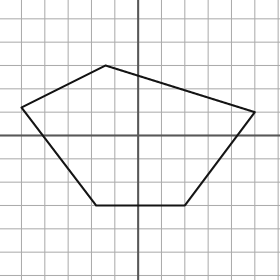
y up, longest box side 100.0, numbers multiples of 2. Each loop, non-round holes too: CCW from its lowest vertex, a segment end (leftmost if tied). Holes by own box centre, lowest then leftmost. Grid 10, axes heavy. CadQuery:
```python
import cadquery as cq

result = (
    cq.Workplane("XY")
    .moveTo(-18.0, -30.0)
    .lineTo(20.0, -30.0)
    .lineTo(50.0, 10.0)
    .lineTo(-14.0, 30.0)
    .lineTo(-50.0, 12.0)
    .close()
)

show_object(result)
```